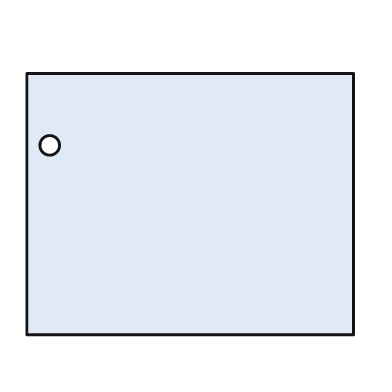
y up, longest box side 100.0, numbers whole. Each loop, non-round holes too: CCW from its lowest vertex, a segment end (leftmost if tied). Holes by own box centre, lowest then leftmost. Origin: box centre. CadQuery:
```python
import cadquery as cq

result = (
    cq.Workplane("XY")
    .moveTo(-50.0, -40.0)
    .lineTo(50.0, -40.0)
    .lineTo(50.0, 40.0)
    .lineTo(-50.0, 40.0)
    .close()
    .moveTo(-43.0, 18.0)
    .circle(3.0)
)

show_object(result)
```